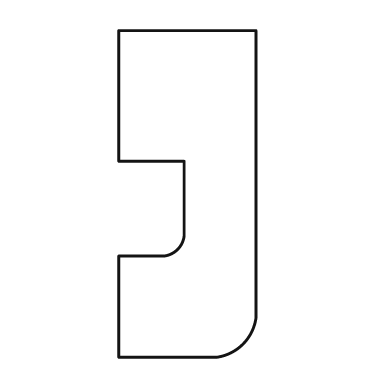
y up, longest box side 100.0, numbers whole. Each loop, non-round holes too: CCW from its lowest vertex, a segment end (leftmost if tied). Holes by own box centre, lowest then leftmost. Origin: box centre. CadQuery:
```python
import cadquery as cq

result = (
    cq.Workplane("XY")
    .moveTo(-21.0, -50.0)
    .lineTo(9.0, -50.0)
    .threePointArc((17.0, -46.0), (21.0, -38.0))
    .lineTo(21.0, 50.0)
    .lineTo(-21.0, 50.0)
    .lineTo(-21.0, 10.0)
    .lineTo(-1.0, 10.0)
    .lineTo(-1.0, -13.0)
    .threePointArc((-3.0, -17.0), (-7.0, -19.0))
    .lineTo(-21.0, -19.0)
    .close()
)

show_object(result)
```